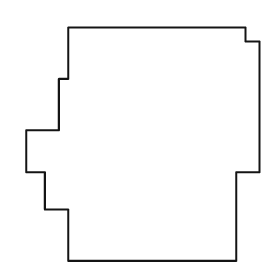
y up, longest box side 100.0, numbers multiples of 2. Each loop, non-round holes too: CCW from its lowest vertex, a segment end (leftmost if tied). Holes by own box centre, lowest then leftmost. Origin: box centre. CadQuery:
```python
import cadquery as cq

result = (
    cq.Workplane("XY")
    .moveTo(-32.0, -50.0)
    .lineTo(40.0, -50.0)
    .lineTo(40.0, -12.0)
    .lineTo(50.0, -12.0)
    .lineTo(50.0, 44.0)
    .lineTo(44.0, 44.0)
    .lineTo(44.0, 50.0)
    .lineTo(-32.0, 50.0)
    .lineTo(-32.0, 28.0)
    .lineTo(-36.0, 28.0)
    .lineTo(-36.0, 6.0)
    .lineTo(-50.0, 6.0)
    .lineTo(-50.0, -12.0)
    .lineTo(-42.0, -12.0)
    .lineTo(-42.0, -28.0)
    .lineTo(-32.0, -28.0)
    .close()
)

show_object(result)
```